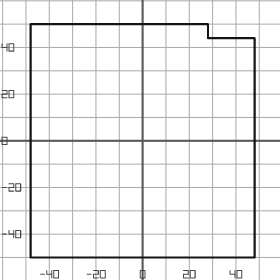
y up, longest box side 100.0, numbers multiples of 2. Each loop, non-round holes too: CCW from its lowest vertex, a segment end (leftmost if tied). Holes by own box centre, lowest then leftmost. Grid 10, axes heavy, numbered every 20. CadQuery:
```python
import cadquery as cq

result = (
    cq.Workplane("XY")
    .moveTo(-48.0, -50.0)
    .lineTo(48.0, -50.0)
    .lineTo(48.0, 44.0)
    .lineTo(28.0, 44.0)
    .lineTo(28.0, 50.0)
    .lineTo(-48.0, 50.0)
    .close()
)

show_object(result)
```